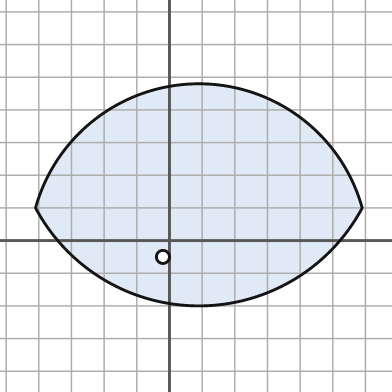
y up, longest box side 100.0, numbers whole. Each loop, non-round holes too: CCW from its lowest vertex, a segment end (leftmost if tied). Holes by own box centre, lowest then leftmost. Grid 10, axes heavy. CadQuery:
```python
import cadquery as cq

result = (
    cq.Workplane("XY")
    .moveTo(-41.0, 10.0)
    .threePointArc((9.0, -20.0), (59.0, 10.0))
    .threePointArc((9.0, 48.0), (-41.0, 10.0))
    .close()
    .moveTo(-2.0, -5.0)
    .circle(2.0)
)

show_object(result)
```